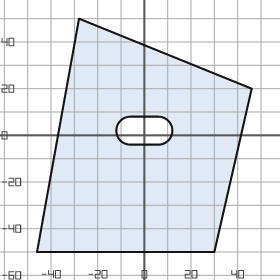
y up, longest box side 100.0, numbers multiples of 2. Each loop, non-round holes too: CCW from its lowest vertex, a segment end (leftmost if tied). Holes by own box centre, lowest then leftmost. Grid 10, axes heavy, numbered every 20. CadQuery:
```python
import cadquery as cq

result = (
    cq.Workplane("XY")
    .moveTo(-46.0, -50.0)
    .lineTo(30.0, -50.0)
    .lineTo(46.0, 20.0)
    .lineTo(-28.0, 50.0)
    .close()
    .moveTo(-6.0, -4.0)
    .lineTo(6.0, -4.0)
    .threePointArc((12.0, 2.0), (6.0, 8.0))
    .lineTo(-6.0, 8.0)
    .threePointArc((-12.0, 2.0), (-6.0, -4.0))
    .close()
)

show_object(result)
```